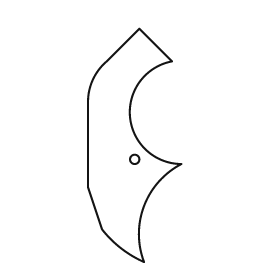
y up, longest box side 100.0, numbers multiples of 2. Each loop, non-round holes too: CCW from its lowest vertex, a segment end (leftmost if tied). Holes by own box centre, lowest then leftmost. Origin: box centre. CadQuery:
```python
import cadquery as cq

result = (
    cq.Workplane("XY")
    .moveTo(4.0, -50.0)
    .threePointArc((4.0, -26.0), (20.0, -8.0))
    .threePointArc((-2.0, 12.0), (16.0, 36.0))
    .lineTo(2.0, 50.0)
    .lineTo(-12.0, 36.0)
    .threePointArc((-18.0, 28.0), (-20.0, 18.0))
    .lineTo(-20.0, -18.0)
    .lineTo(-14.0, -36.0)
    .threePointArc((-6.0, -44.0), (4.0, -50.0))
    .close()
    .moveTo(0.0, -6.0)
    .circle(2.0)
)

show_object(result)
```